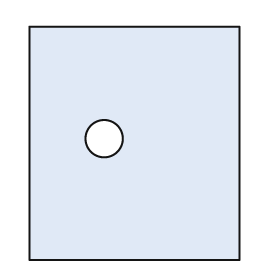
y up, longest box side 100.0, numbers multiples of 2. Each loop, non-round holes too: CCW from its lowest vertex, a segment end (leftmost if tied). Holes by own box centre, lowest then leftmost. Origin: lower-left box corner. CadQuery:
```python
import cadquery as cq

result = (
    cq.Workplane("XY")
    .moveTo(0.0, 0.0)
    .lineTo(90.0, 0.0)
    .lineTo(90.0, 100.0)
    .lineTo(0.0, 100.0)
    .close()
    .moveTo(32.0, 52.0)
    .circle(8.0)
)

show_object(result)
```